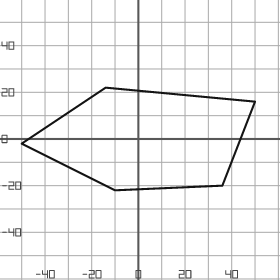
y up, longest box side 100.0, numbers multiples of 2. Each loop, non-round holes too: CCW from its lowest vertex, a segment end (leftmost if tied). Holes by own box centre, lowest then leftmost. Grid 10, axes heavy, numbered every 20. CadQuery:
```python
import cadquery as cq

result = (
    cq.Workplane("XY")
    .moveTo(-10.0, -22.0)
    .lineTo(36.0, -20.0)
    .lineTo(50.0, 16.0)
    .lineTo(-14.0, 22.0)
    .lineTo(-50.0, -2.0)
    .close()
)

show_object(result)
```